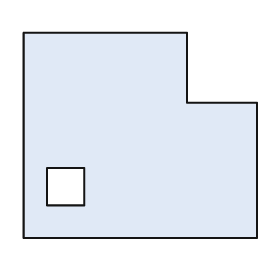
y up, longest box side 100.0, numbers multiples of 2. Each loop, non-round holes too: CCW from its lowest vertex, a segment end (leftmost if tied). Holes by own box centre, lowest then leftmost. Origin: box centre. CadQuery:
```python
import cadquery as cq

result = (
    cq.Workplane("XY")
    .moveTo(-50.0, -44.0)
    .lineTo(50.0, -44.0)
    .lineTo(50.0, 14.0)
    .lineTo(20.0, 14.0)
    .lineTo(20.0, 44.0)
    .lineTo(-50.0, 44.0)
    .close()
    .moveTo(-40.0, -30.0)
    .lineTo(-24.0, -30.0)
    .lineTo(-24.0, -14.0)
    .lineTo(-40.0, -14.0)
    .close()
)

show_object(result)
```